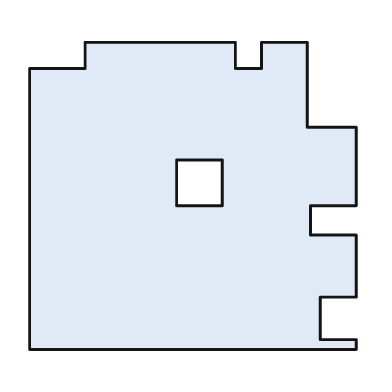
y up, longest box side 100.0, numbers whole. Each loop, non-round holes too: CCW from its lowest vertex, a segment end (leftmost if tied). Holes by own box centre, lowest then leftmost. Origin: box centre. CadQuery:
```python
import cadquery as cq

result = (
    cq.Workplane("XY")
    .moveTo(-50.0, -47.0)
    .lineTo(50.0, -47.0)
    .lineTo(50.0, -44.0)
    .lineTo(39.0, -44.0)
    .lineTo(39.0, -31.0)
    .lineTo(50.0, -31.0)
    .lineTo(50.0, -12.0)
    .lineTo(36.0, -12.0)
    .lineTo(36.0, -3.0)
    .lineTo(50.0, -3.0)
    .lineTo(50.0, 21.0)
    .lineTo(35.0, 21.0)
    .lineTo(35.0, 47.0)
    .lineTo(21.0, 47.0)
    .lineTo(21.0, 39.0)
    .lineTo(13.0, 39.0)
    .lineTo(13.0, 47.0)
    .lineTo(-33.0, 47.0)
    .lineTo(-33.0, 39.0)
    .lineTo(-50.0, 39.0)
    .close()
    .moveTo(-5.0, -3.0)
    .lineTo(9.0, -3.0)
    .lineTo(9.0, 11.0)
    .lineTo(-5.0, 11.0)
    .close()
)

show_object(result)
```